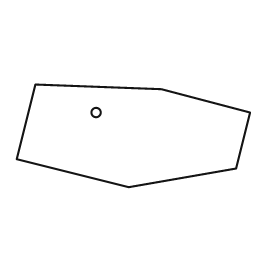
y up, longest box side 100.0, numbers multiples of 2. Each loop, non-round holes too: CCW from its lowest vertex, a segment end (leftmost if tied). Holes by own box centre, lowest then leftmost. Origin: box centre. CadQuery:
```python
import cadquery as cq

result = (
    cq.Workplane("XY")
    .moveTo(-2.0, -22.0)
    .lineTo(44.0, -14.0)
    .lineTo(50.0, 10.0)
    .lineTo(12.0, 20.0)
    .lineTo(-42.0, 22.0)
    .lineTo(-50.0, -10.0)
    .close()
    .moveTo(-16.0, 10.0)
    .circle(2.0)
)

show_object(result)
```